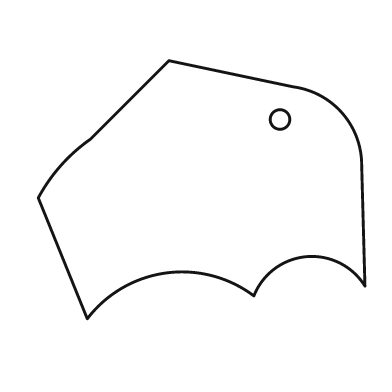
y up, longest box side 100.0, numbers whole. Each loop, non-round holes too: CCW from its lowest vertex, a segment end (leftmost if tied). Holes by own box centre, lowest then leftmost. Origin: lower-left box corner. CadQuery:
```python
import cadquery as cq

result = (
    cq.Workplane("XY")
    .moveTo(15.0, 0.0)
    .threePointArc((39.0, 14.0), (66.0, 7.0))
    .threePointArc((82.0, 19.0), (100.0, 10.0))
    .lineTo(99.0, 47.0)
    .threePointArc((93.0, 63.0), (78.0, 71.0))
    .lineTo(40.0, 79.0)
    .lineTo(16.0, 55.0)
    .threePointArc((7.0, 47.0), (0.0, 37.0))
    .close()
    .moveTo(74.0, 61.0)
    .circle(3.0)
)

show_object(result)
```